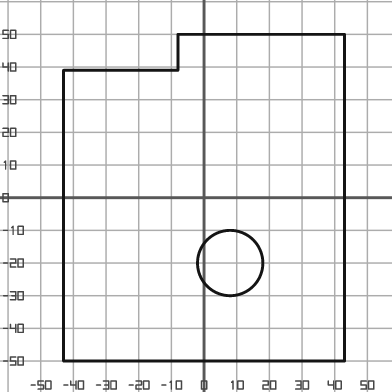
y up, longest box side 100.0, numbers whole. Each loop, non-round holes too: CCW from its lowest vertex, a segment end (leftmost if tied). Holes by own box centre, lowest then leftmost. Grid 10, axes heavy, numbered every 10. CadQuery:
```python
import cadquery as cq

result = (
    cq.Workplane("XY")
    .moveTo(-43.0, -50.0)
    .lineTo(43.0, -50.0)
    .lineTo(43.0, 50.0)
    .lineTo(-8.0, 50.0)
    .lineTo(-8.0, 39.0)
    .lineTo(-43.0, 39.0)
    .close()
    .moveTo(8.0, -20.0)
    .circle(10.0)
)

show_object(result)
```